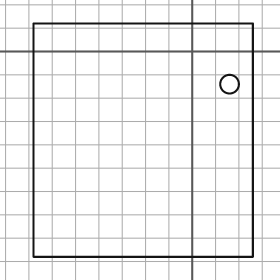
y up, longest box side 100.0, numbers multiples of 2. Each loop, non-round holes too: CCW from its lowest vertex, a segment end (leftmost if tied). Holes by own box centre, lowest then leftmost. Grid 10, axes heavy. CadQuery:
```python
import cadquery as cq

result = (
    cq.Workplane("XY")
    .moveTo(-68.0, -88.0)
    .lineTo(26.0, -88.0)
    .lineTo(26.0, 12.0)
    .lineTo(-68.0, 12.0)
    .close()
    .moveTo(16.0, -14.0)
    .circle(4.0)
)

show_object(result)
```